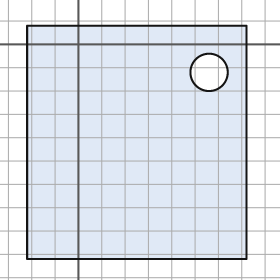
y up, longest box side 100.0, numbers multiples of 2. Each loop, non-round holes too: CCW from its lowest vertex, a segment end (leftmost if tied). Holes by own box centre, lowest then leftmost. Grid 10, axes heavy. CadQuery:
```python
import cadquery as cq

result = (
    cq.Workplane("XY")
    .moveTo(-22.0, -92.0)
    .lineTo(72.0, -92.0)
    .lineTo(72.0, 8.0)
    .lineTo(-22.0, 8.0)
    .close()
    .moveTo(56.0, -12.0)
    .circle(8.0)
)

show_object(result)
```